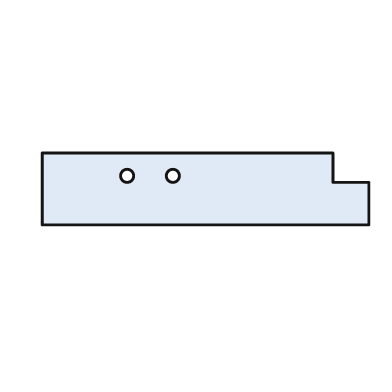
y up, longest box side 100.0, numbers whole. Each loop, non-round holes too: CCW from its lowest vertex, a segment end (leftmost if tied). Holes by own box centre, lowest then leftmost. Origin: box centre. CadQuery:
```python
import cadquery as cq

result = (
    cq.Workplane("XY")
    .moveTo(-50.0, -11.0)
    .lineTo(50.0, -11.0)
    .lineTo(50.0, 2.0)
    .lineTo(39.0, 2.0)
    .lineTo(39.0, 11.0)
    .lineTo(-50.0, 11.0)
    .close()
    .moveTo(-24.0, 4.0)
    .circle(2.0)
    .moveTo(-10.0, 4.0)
    .circle(2.0)
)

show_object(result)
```